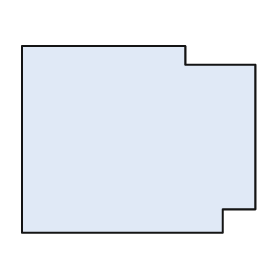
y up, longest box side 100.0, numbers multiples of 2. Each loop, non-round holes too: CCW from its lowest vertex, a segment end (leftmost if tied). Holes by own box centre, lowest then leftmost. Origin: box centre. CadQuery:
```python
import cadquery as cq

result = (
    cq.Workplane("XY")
    .moveTo(-50.0, -40.0)
    .lineTo(36.0, -40.0)
    .lineTo(36.0, -30.0)
    .lineTo(50.0, -30.0)
    .lineTo(50.0, 32.0)
    .lineTo(20.0, 32.0)
    .lineTo(20.0, 40.0)
    .lineTo(-50.0, 40.0)
    .close()
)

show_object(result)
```